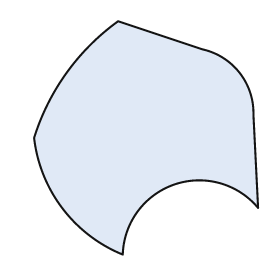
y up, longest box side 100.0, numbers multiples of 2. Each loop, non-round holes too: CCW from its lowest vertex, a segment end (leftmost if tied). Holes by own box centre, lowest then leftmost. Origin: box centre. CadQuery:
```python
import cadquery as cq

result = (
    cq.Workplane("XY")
    .moveTo(-10.0, -50.0)
    .threePointArc((12.0, -20.0), (48.0, -30.0))
    .lineTo(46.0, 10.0)
    .threePointArc((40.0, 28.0), (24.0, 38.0))
    .lineTo(-12.0, 50.0)
    .threePointArc((-34.0, 28.0), (-48.0, 0.0))
    .threePointArc((-36.0, -30.0), (-10.0, -50.0))
    .close()
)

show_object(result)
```